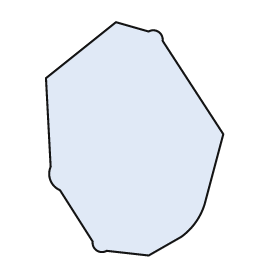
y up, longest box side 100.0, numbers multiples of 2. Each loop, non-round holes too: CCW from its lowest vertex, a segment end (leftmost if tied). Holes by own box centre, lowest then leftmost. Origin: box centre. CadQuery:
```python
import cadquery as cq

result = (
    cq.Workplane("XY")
    .moveTo(6.0, -50.0)
    .lineTo(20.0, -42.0)
    .threePointArc((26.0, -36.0), (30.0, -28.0))
    .lineTo(38.0, 2.0)
    .lineTo(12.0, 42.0)
    .threePointArc((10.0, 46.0), (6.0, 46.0))
    .lineTo(-8.0, 50.0)
    .lineTo(-38.0, 26.0)
    .lineTo(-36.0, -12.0)
    .threePointArc((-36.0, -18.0), (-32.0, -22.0))
    .lineTo(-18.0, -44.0)
    .threePointArc((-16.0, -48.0), (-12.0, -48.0))
    .close()
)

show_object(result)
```